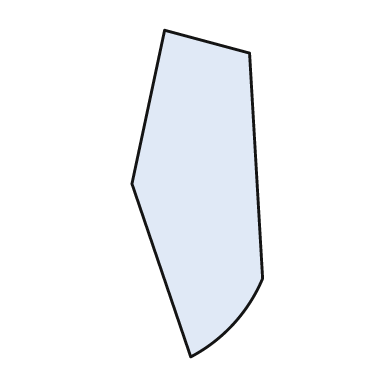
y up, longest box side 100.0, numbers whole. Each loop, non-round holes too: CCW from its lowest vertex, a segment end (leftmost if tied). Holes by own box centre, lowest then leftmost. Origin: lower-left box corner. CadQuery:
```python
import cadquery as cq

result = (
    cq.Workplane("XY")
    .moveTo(18.0, 0.0)
    .threePointArc((31.0, 10.0), (40.0, 24.0))
    .lineTo(36.0, 93.0)
    .lineTo(10.0, 100.0)
    .lineTo(0.0, 53.0)
    .close()
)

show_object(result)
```